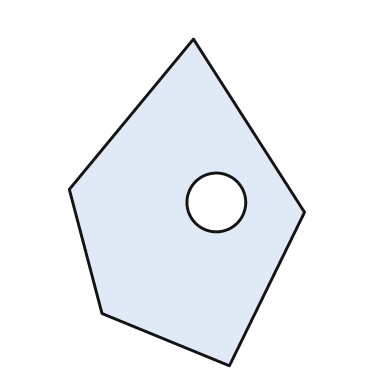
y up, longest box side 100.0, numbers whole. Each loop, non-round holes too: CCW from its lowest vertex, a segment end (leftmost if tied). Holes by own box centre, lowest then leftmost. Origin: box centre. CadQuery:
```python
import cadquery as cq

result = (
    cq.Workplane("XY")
    .moveTo(13.0, -50.0)
    .lineTo(36.0, -3.0)
    .lineTo(2.0, 50.0)
    .lineTo(-36.0, 4.0)
    .lineTo(-26.0, -34.0)
    .close()
    .moveTo(9.0, 0.0)
    .circle(9.0)
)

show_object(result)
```